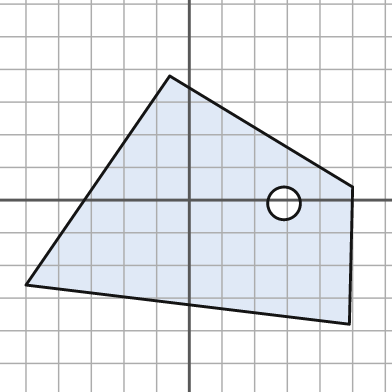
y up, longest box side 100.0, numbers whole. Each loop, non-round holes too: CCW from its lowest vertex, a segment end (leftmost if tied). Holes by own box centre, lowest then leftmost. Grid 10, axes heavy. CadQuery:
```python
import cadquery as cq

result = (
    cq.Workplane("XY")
    .moveTo(49.0, -38.0)
    .lineTo(50.0, 4.0)
    .lineTo(-6.0, 38.0)
    .lineTo(-50.0, -26.0)
    .close()
    .moveTo(29.0, -1.0)
    .circle(5.0)
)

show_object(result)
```